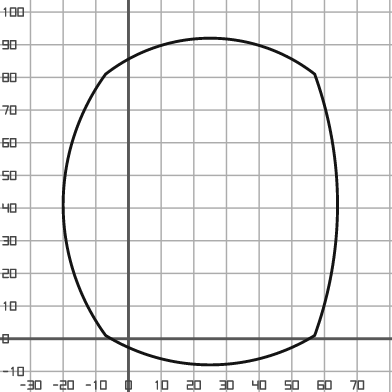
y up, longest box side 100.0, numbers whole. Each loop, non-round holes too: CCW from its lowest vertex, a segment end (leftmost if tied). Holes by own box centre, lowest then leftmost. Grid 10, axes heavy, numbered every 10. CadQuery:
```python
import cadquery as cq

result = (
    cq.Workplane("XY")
    .moveTo(-7.0, 1.0)
    .threePointArc((25.0, -8.0), (57.0, 1.0))
    .threePointArc((64.0, 41.0), (57.0, 81.0))
    .threePointArc((25.0, 92.0), (-7.0, 81.0))
    .threePointArc((-20.0, 41.0), (-7.0, 1.0))
    .close()
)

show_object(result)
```